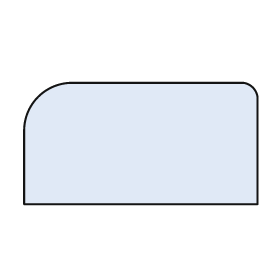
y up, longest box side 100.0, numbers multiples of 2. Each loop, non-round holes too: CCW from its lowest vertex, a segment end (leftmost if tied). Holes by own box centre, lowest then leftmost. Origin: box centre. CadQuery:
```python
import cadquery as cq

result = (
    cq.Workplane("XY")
    .moveTo(-50.0, -26.0)
    .lineTo(50.0, -26.0)
    .lineTo(50.0, 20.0)
    .threePointArc((48.0, 24.0), (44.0, 26.0))
    .lineTo(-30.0, 26.0)
    .threePointArc((-44.0, 20.0), (-50.0, 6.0))
    .close()
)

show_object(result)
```